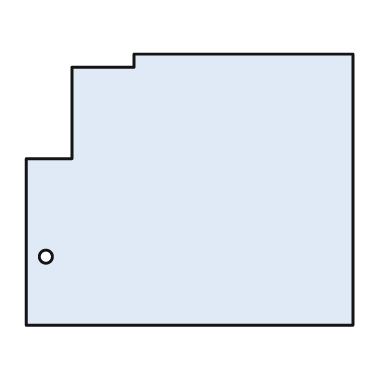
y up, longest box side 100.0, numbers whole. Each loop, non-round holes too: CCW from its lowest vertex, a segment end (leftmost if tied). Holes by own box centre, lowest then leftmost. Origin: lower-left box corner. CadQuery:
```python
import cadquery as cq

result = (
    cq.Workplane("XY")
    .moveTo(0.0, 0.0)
    .lineTo(100.0, 0.0)
    .lineTo(100.0, 83.0)
    .lineTo(33.0, 83.0)
    .lineTo(33.0, 79.0)
    .lineTo(14.0, 79.0)
    .lineTo(14.0, 51.0)
    .lineTo(0.0, 51.0)
    .close()
    .moveTo(6.0, 21.0)
    .circle(2.0)
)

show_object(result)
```